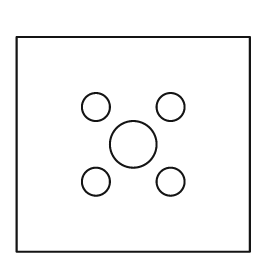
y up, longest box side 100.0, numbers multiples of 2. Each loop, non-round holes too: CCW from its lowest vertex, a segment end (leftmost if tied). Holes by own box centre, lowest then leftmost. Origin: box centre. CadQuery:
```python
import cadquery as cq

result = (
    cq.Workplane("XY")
    .moveTo(-50.0, -46.0)
    .lineTo(50.0, -46.0)
    .lineTo(50.0, 46.0)
    .lineTo(-50.0, 46.0)
    .close()
    .moveTo(-16.0, -16.0)
    .circle(6.0)
    .moveTo(16.0, -16.0)
    .circle(6.0)
    .moveTo(0.0, 0.0)
    .circle(10.0)
    .moveTo(-16.0, 16.0)
    .circle(6.0)
    .moveTo(16.0, 16.0)
    .circle(6.0)
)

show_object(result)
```